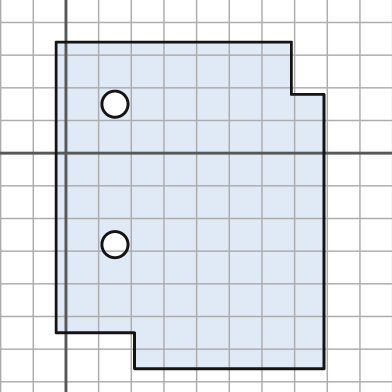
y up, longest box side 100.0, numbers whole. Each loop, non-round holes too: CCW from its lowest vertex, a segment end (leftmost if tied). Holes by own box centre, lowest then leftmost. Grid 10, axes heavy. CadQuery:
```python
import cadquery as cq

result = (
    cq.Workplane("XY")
    .moveTo(21.0, -66.0)
    .lineTo(79.0, -66.0)
    .lineTo(79.0, 18.0)
    .lineTo(69.0, 18.0)
    .lineTo(69.0, 34.0)
    .lineTo(-3.0, 34.0)
    .lineTo(-3.0, -55.0)
    .lineTo(21.0, -55.0)
    .close()
    .moveTo(15.0, -28.0)
    .circle(4.0)
    .moveTo(15.0, 15.0)
    .circle(4.0)
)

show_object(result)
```